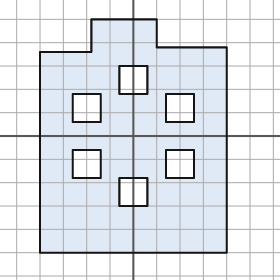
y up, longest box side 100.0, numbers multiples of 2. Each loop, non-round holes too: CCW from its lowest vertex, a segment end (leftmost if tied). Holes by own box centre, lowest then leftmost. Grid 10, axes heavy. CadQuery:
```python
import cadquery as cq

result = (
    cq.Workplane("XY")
    .moveTo(-40.0, -50.0)
    .lineTo(40.0, -50.0)
    .lineTo(40.0, 38.0)
    .lineTo(10.0, 38.0)
    .lineTo(10.0, 50.0)
    .lineTo(-18.0, 50.0)
    .lineTo(-18.0, 36.0)
    .lineTo(-40.0, 36.0)
    .close()
    .moveTo(-6.0, -30.0)
    .lineTo(6.0, -30.0)
    .lineTo(6.0, -18.0)
    .lineTo(-6.0, -18.0)
    .close()
    .moveTo(-26.0, -18.0)
    .lineTo(-14.0, -18.0)
    .lineTo(-14.0, -6.0)
    .lineTo(-26.0, -6.0)
    .close()
    .moveTo(14.0, -18.0)
    .lineTo(26.0, -18.0)
    .lineTo(26.0, -6.0)
    .lineTo(14.0, -6.0)
    .close()
    .moveTo(-26.0, 6.0)
    .lineTo(-14.0, 6.0)
    .lineTo(-14.0, 18.0)
    .lineTo(-26.0, 18.0)
    .close()
    .moveTo(14.0, 6.0)
    .lineTo(26.0, 6.0)
    .lineTo(26.0, 18.0)
    .lineTo(14.0, 18.0)
    .close()
    .moveTo(-6.0, 18.0)
    .lineTo(6.0, 18.0)
    .lineTo(6.0, 30.0)
    .lineTo(-6.0, 30.0)
    .close()
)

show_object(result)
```